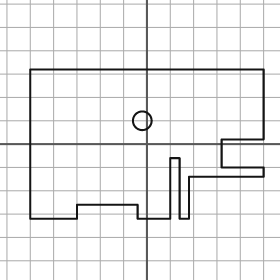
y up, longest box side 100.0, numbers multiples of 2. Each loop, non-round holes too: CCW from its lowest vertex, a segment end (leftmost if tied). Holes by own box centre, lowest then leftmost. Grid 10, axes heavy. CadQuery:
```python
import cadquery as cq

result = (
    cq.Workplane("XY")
    .moveTo(-50.0, -32.0)
    .lineTo(-30.0, -32.0)
    .lineTo(-30.0, -26.0)
    .lineTo(-4.0, -26.0)
    .lineTo(-4.0, -32.0)
    .lineTo(10.0, -32.0)
    .lineTo(10.0, -6.0)
    .lineTo(14.0, -6.0)
    .lineTo(14.0, -32.0)
    .lineTo(18.0, -32.0)
    .lineTo(18.0, -14.0)
    .lineTo(50.0, -14.0)
    .lineTo(50.0, -10.0)
    .lineTo(32.0, -10.0)
    .lineTo(32.0, 2.0)
    .lineTo(50.0, 2.0)
    .lineTo(50.0, 32.0)
    .lineTo(-50.0, 32.0)
    .close()
    .moveTo(-2.0, 10.0)
    .circle(4.0)
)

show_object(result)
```